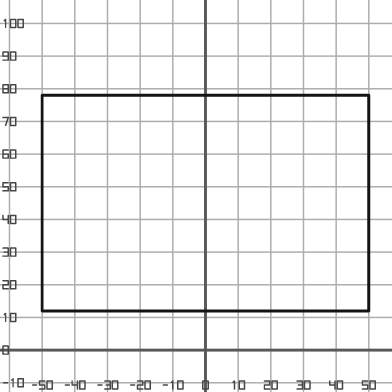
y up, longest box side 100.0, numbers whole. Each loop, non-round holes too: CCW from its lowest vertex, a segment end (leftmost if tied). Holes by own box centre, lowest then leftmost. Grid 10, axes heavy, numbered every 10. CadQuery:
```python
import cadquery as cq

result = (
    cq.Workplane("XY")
    .moveTo(-50.0, 12.0)
    .lineTo(50.0, 12.0)
    .lineTo(50.0, 78.0)
    .lineTo(-50.0, 78.0)
    .close()
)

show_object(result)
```